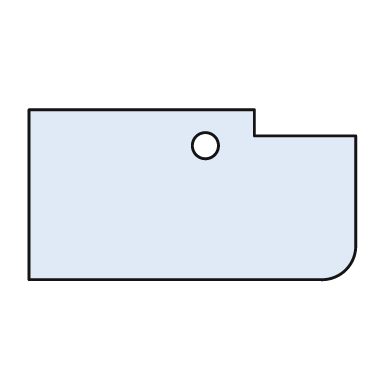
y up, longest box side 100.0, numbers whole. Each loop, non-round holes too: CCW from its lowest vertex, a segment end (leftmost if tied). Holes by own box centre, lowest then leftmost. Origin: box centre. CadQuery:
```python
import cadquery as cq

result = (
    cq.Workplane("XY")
    .moveTo(-50.0, -26.0)
    .lineTo(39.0, -26.0)
    .threePointArc((47.0, -23.0), (50.0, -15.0))
    .lineTo(50.0, 18.0)
    .lineTo(19.0, 18.0)
    .lineTo(19.0, 26.0)
    .lineTo(-50.0, 26.0)
    .close()
    .moveTo(4.0, 15.0)
    .circle(4.0)
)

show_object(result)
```